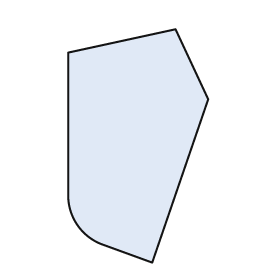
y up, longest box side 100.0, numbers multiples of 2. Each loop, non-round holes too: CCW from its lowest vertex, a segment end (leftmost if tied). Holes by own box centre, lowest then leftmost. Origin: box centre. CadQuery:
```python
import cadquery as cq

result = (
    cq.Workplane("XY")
    .moveTo(6.0, -50.0)
    .lineTo(30.0, 20.0)
    .lineTo(16.0, 50.0)
    .lineTo(-30.0, 40.0)
    .lineTo(-30.0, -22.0)
    .threePointArc((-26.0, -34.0), (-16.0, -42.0))
    .close()
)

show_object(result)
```